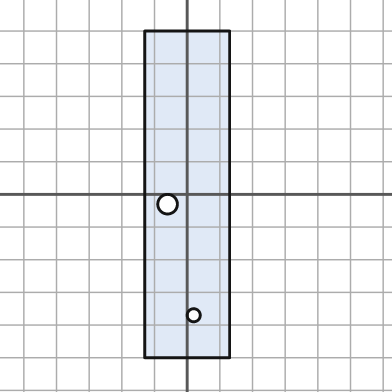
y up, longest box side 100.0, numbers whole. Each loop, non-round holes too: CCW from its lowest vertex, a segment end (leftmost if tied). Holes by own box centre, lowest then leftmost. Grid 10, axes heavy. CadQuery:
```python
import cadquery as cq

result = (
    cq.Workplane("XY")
    .moveTo(-13.0, -50.0)
    .lineTo(13.0, -50.0)
    .lineTo(13.0, 50.0)
    .lineTo(-13.0, 50.0)
    .close()
    .moveTo(2.0, -37.0)
    .circle(2.0)
    .moveTo(-6.0, -3.0)
    .circle(3.0)
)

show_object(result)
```